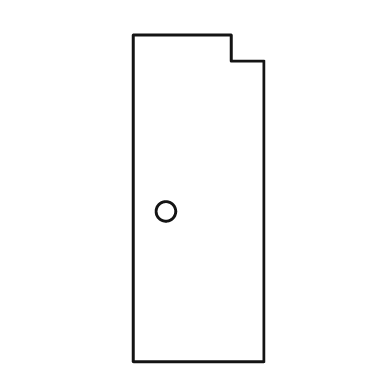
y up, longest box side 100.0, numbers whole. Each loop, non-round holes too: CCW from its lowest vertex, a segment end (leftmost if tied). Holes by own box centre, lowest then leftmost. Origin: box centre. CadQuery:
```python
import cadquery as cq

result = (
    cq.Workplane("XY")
    .moveTo(-20.0, -50.0)
    .lineTo(20.0, -50.0)
    .lineTo(20.0, 42.0)
    .lineTo(10.0, 42.0)
    .lineTo(10.0, 50.0)
    .lineTo(-20.0, 50.0)
    .close()
    .moveTo(-10.0, -4.0)
    .circle(3.0)
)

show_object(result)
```